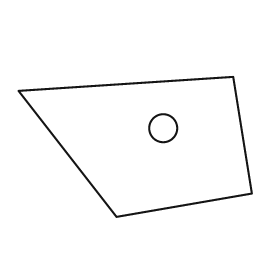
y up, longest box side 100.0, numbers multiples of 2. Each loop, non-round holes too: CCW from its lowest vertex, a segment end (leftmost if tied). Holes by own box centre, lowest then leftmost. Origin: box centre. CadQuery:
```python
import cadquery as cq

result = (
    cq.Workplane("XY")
    .moveTo(-8.0, -30.0)
    .lineTo(50.0, -20.0)
    .lineTo(42.0, 30.0)
    .lineTo(-50.0, 24.0)
    .close()
    .moveTo(12.0, 8.0)
    .circle(6.0)
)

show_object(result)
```